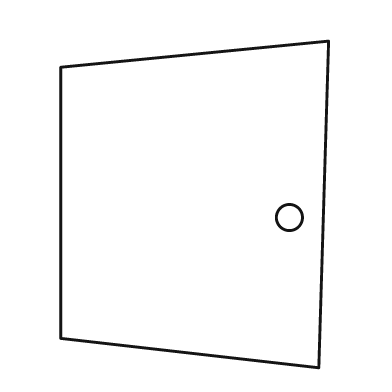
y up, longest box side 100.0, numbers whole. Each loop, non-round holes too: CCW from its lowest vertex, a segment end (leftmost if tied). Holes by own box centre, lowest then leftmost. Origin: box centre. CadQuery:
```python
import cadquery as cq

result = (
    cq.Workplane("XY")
    .moveTo(38.0, -50.0)
    .lineTo(41.0, 50.0)
    .lineTo(-41.0, 42.0)
    .lineTo(-41.0, -41.0)
    .close()
    .moveTo(29.0, -4.0)
    .circle(4.0)
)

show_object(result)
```